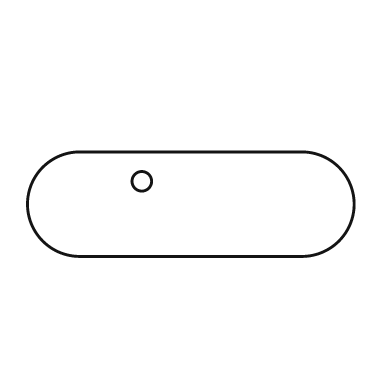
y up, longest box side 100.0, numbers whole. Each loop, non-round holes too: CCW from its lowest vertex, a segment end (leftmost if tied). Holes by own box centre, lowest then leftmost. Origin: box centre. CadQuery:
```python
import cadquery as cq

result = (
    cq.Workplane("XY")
    .moveTo(-34.0, -16.0)
    .lineTo(34.0, -16.0)
    .threePointArc((50.0, 0.0), (34.0, 16.0))
    .lineTo(-34.0, 16.0)
    .threePointArc((-50.0, 0.0), (-34.0, -16.0))
    .close()
    .moveTo(-15.0, 7.0)
    .circle(3.0)
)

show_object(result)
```